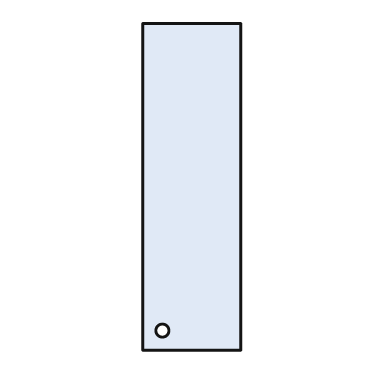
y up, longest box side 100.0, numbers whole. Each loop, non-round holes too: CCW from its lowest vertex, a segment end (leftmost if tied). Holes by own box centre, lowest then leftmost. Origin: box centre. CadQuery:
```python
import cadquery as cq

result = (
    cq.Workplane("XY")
    .moveTo(-15.0, -50.0)
    .lineTo(15.0, -50.0)
    .lineTo(15.0, 50.0)
    .lineTo(-15.0, 50.0)
    .close()
    .moveTo(-9.0, -44.0)
    .circle(2.0)
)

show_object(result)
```